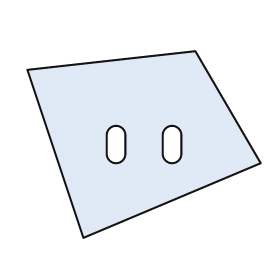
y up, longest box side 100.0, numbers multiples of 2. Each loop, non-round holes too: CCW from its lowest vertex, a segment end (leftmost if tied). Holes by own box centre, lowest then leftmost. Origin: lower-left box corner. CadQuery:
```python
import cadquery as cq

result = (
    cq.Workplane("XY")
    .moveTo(24.0, 0.0)
    .lineTo(100.0, 32.0)
    .lineTo(72.0, 80.0)
    .lineTo(0.0, 72.0)
    .close()
    .moveTo(34.0, 36.0)
    .threePointArc((38.0, 32.0), (42.0, 36.0))
    .lineTo(42.0, 44.0)
    .threePointArc((38.0, 48.0), (34.0, 44.0))
    .close()
    .moveTo(58.0, 36.0)
    .threePointArc((62.0, 32.0), (66.0, 36.0))
    .lineTo(66.0, 44.0)
    .threePointArc((62.0, 48.0), (58.0, 44.0))
    .close()
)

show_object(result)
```